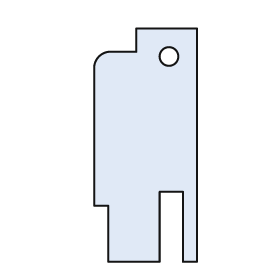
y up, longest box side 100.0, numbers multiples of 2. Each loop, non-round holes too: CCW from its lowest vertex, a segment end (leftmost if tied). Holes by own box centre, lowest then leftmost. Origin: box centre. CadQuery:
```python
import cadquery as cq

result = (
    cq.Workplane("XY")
    .moveTo(-16.0, -50.0)
    .lineTo(6.0, -50.0)
    .lineTo(6.0, -20.0)
    .lineTo(16.0, -20.0)
    .lineTo(16.0, -50.0)
    .lineTo(22.0, -50.0)
    .lineTo(22.0, 50.0)
    .lineTo(-4.0, 50.0)
    .lineTo(-4.0, 40.0)
    .lineTo(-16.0, 40.0)
    .threePointArc((-20.0, 38.0), (-22.0, 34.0))
    .lineTo(-22.0, -26.0)
    .lineTo(-16.0, -26.0)
    .close()
    .moveTo(10.0, 38.0)
    .circle(4.0)
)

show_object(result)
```